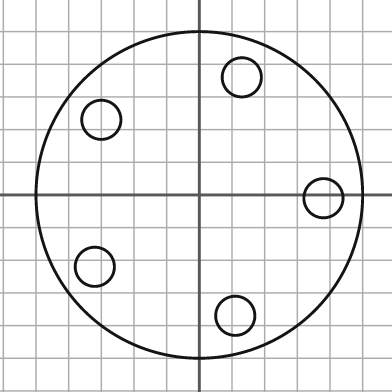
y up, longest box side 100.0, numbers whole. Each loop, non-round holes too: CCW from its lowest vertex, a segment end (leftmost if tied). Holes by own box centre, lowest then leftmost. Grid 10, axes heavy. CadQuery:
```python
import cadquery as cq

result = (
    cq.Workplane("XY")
    .moveTo(0.0, 0.0)
    .circle(50.0)
    .moveTo(11.0, -37.0)
    .circle(6.0)
    .moveTo(-32.0, -22.0)
    .circle(6.0)
    .moveTo(38.0, -1.0)
    .circle(6.0)
    .moveTo(-30.0, 23.0)
    .circle(6.0)
    .moveTo(13.0, 36.0)
    .circle(6.0)
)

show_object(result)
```